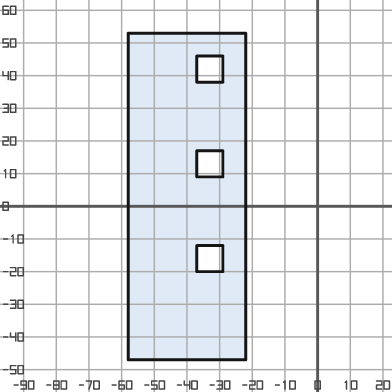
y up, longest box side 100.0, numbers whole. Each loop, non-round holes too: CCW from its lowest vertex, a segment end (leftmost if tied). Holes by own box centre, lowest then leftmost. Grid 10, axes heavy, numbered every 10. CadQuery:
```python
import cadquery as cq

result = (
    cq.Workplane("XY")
    .moveTo(-58.0, -47.0)
    .lineTo(-22.0, -47.0)
    .lineTo(-22.0, 53.0)
    .lineTo(-58.0, 53.0)
    .close()
    .moveTo(-37.0, -20.0)
    .lineTo(-29.0, -20.0)
    .lineTo(-29.0, -12.0)
    .lineTo(-37.0, -12.0)
    .close()
    .moveTo(-37.0, 9.0)
    .lineTo(-29.0, 9.0)
    .lineTo(-29.0, 17.0)
    .lineTo(-37.0, 17.0)
    .close()
    .moveTo(-37.0, 38.0)
    .lineTo(-29.0, 38.0)
    .lineTo(-29.0, 46.0)
    .lineTo(-37.0, 46.0)
    .close()
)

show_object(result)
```